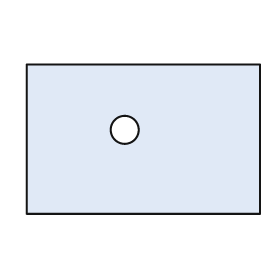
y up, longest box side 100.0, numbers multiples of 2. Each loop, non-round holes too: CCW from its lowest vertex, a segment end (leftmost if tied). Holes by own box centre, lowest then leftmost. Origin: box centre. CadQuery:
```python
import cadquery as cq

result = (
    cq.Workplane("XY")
    .moveTo(-50.0, -32.0)
    .lineTo(50.0, -32.0)
    .lineTo(50.0, 32.0)
    .lineTo(-50.0, 32.0)
    .close()
    .moveTo(-8.0, 4.0)
    .circle(6.0)
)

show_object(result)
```